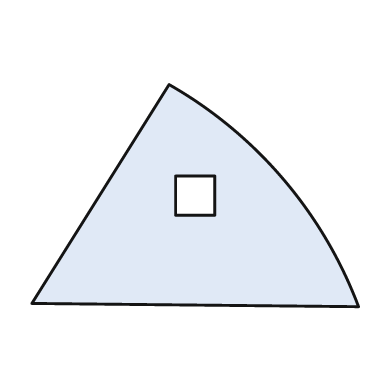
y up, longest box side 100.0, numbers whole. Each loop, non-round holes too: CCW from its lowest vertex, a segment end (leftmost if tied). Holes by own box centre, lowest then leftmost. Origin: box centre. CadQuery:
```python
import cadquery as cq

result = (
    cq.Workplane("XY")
    .moveTo(50.0, -34.0)
    .threePointArc((27.0, 5.0), (-8.0, 34.0))
    .lineTo(-50.0, -33.0)
    .close()
    .moveTo(-6.0, -6.0)
    .lineTo(6.0, -6.0)
    .lineTo(6.0, 6.0)
    .lineTo(-6.0, 6.0)
    .close()
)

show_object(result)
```